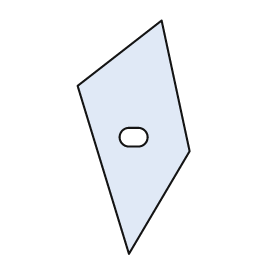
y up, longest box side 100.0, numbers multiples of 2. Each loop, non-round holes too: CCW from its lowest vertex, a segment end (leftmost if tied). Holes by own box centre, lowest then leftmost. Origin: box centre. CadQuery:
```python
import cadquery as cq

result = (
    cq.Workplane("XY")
    .moveTo(-2.0, -50.0)
    .lineTo(24.0, -6.0)
    .lineTo(12.0, 50.0)
    .lineTo(-24.0, 22.0)
    .close()
    .moveTo(-2.0, -4.0)
    .lineTo(2.0, -4.0)
    .threePointArc((6.0, 0.0), (2.0, 4.0))
    .lineTo(-2.0, 4.0)
    .threePointArc((-6.0, 0.0), (-2.0, -4.0))
    .close()
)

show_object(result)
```